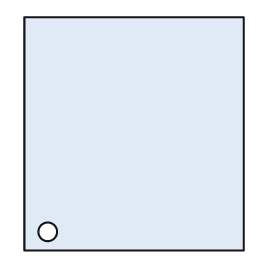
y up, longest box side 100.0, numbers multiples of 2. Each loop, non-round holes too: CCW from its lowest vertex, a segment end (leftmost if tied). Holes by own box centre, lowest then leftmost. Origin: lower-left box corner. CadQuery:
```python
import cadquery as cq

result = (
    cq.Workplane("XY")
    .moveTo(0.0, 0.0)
    .lineTo(94.0, 0.0)
    .lineTo(94.0, 100.0)
    .lineTo(0.0, 100.0)
    .close()
    .moveTo(10.0, 8.0)
    .circle(4.0)
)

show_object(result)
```